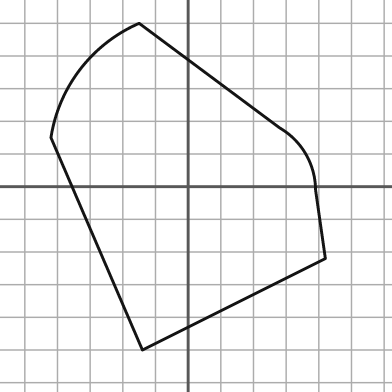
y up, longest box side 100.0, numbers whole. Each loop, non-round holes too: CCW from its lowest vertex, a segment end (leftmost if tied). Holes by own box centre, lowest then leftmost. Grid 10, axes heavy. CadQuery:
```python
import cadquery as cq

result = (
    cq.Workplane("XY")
    .moveTo(-14.0, -50.0)
    .lineTo(42.0, -22.0)
    .lineTo(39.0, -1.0)
    .threePointArc((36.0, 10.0), (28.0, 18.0))
    .lineTo(-15.0, 50.0)
    .threePointArc((-33.0, 36.0), (-42.0, 15.0))
    .close()
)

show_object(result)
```